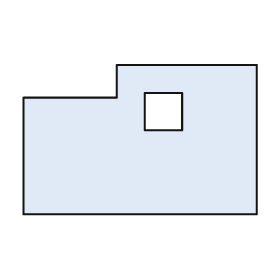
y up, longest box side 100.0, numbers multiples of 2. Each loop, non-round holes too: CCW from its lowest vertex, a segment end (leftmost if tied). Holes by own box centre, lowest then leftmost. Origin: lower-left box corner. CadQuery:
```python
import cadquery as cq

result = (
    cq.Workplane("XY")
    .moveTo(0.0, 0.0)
    .lineTo(100.0, 0.0)
    .lineTo(100.0, 64.0)
    .lineTo(40.0, 64.0)
    .lineTo(40.0, 50.0)
    .lineTo(0.0, 50.0)
    .close()
    .moveTo(52.0, 36.0)
    .lineTo(68.0, 36.0)
    .lineTo(68.0, 52.0)
    .lineTo(52.0, 52.0)
    .close()
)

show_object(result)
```